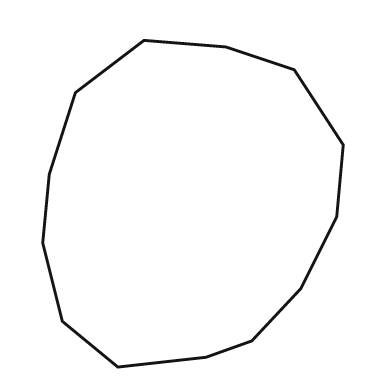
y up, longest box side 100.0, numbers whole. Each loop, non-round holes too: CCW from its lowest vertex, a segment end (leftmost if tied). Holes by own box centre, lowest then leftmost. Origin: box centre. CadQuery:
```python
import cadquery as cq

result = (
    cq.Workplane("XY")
    .moveTo(-23.0, -50.0)
    .lineTo(4.0, -47.0)
    .lineTo(18.0, -42.0)
    .lineTo(33.0, -26.0)
    .lineTo(44.0, -4.0)
    .lineTo(46.0, 18.0)
    .lineTo(31.0, 41.0)
    .lineTo(10.0, 48.0)
    .lineTo(-15.0, 50.0)
    .lineTo(-36.0, 34.0)
    .lineTo(-44.0, 9.0)
    .lineTo(-46.0, -12.0)
    .lineTo(-40.0, -36.0)
    .close()
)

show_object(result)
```